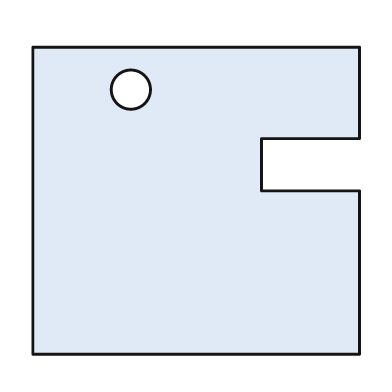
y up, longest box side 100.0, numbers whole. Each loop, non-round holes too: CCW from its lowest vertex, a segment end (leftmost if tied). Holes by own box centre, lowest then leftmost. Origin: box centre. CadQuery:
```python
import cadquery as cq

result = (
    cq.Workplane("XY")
    .moveTo(-50.0, -47.0)
    .lineTo(50.0, -47.0)
    .lineTo(50.0, 3.0)
    .lineTo(20.0, 3.0)
    .lineTo(20.0, 19.0)
    .lineTo(50.0, 19.0)
    .lineTo(50.0, 47.0)
    .lineTo(-50.0, 47.0)
    .close()
    .moveTo(-20.0, 34.0)
    .circle(6.0)
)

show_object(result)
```